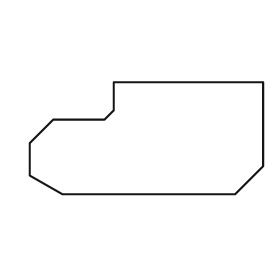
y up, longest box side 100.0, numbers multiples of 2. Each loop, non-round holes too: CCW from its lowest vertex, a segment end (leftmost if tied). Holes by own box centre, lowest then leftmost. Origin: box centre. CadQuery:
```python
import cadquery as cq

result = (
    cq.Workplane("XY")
    .moveTo(-36.0, -24.0)
    .lineTo(38.0, -24.0)
    .lineTo(50.0, -12.0)
    .lineTo(50.0, 24.0)
    .lineTo(-14.0, 24.0)
    .lineTo(-14.0, 12.0)
    .lineTo(-18.0, 8.0)
    .lineTo(-40.0, 8.0)
    .lineTo(-50.0, -2.0)
    .lineTo(-50.0, -16.0)
    .close()
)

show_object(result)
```